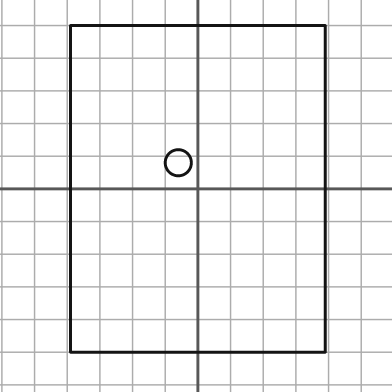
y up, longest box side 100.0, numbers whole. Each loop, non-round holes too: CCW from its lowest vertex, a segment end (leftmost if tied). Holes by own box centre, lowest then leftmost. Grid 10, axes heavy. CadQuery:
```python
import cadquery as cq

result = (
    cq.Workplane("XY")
    .moveTo(-39.0, -50.0)
    .lineTo(39.0, -50.0)
    .lineTo(39.0, 50.0)
    .lineTo(-39.0, 50.0)
    .close()
    .moveTo(-6.0, 8.0)
    .circle(4.0)
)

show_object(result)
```